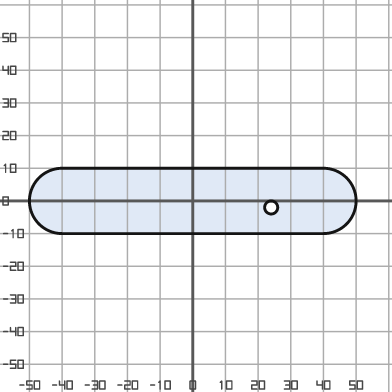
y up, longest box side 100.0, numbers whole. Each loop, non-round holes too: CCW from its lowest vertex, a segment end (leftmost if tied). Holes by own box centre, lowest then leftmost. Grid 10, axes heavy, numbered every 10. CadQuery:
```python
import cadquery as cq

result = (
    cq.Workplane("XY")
    .moveTo(-40.0, -10.0)
    .lineTo(40.0, -10.0)
    .threePointArc((50.0, 0.0), (40.0, 10.0))
    .lineTo(-40.0, 10.0)
    .threePointArc((-50.0, 0.0), (-40.0, -10.0))
    .close()
    .moveTo(24.0, -2.0)
    .circle(2.0)
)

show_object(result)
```